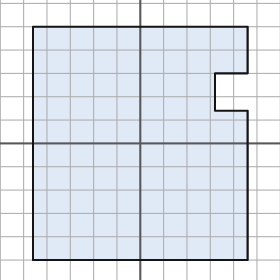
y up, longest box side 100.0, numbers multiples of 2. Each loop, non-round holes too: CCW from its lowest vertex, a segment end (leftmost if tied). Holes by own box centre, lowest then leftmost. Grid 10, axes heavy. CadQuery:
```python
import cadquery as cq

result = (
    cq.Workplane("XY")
    .moveTo(-46.0, -50.0)
    .lineTo(46.0, -50.0)
    .lineTo(46.0, 14.0)
    .lineTo(32.0, 14.0)
    .lineTo(32.0, 30.0)
    .lineTo(46.0, 30.0)
    .lineTo(46.0, 50.0)
    .lineTo(-46.0, 50.0)
    .close()
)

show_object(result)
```